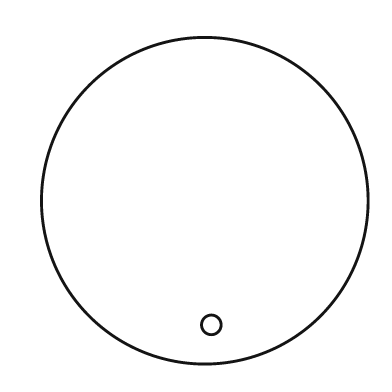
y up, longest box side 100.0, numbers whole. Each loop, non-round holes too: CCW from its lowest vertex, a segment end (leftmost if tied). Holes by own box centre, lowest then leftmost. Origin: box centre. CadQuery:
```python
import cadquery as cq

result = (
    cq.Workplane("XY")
    .moveTo(0.0, 0.0)
    .circle(50.0)
    .moveTo(2.0, -38.0)
    .circle(3.0)
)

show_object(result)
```